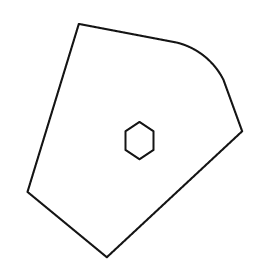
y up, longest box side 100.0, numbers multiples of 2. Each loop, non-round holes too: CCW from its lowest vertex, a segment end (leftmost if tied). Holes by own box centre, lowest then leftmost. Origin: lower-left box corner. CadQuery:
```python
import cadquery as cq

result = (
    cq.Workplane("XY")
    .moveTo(34.0, 0.0)
    .lineTo(92.0, 54.0)
    .lineTo(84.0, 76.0)
    .threePointArc((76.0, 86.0), (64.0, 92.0))
    .lineTo(22.0, 100.0)
    .lineTo(0.0, 28.0)
    .close()
    .moveTo(48.0, 42.0)
    .lineTo(54.0, 46.0)
    .lineTo(54.0, 54.0)
    .lineTo(48.0, 58.0)
    .lineTo(42.0, 54.0)
    .lineTo(42.0, 46.0)
    .close()
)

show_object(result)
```